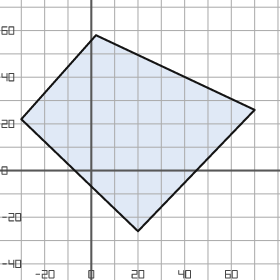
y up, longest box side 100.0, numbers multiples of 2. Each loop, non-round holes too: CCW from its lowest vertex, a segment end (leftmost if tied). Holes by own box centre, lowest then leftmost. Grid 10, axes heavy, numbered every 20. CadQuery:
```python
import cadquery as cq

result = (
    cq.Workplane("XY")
    .moveTo(20.0, -26.0)
    .lineTo(70.0, 26.0)
    .lineTo(2.0, 58.0)
    .lineTo(-30.0, 22.0)
    .close()
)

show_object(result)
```